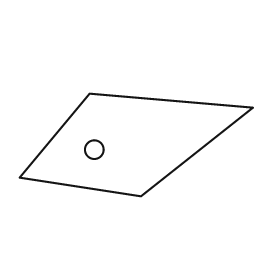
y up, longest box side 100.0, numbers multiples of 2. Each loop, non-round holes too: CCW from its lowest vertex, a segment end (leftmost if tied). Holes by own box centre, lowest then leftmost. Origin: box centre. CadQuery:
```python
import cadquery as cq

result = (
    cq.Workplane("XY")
    .moveTo(2.0, -22.0)
    .lineTo(50.0, 16.0)
    .lineTo(-20.0, 22.0)
    .lineTo(-50.0, -14.0)
    .close()
    .moveTo(-18.0, -2.0)
    .circle(4.0)
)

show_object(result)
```